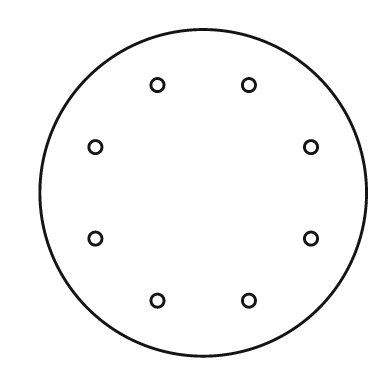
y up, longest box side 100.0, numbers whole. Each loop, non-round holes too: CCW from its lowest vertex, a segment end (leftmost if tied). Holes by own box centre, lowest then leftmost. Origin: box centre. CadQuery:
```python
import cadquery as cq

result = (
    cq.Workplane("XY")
    .moveTo(0.0, 0.0)
    .circle(50.0)
    .moveTo(-14.0, -33.0)
    .circle(2.0)
    .moveTo(14.0, -33.0)
    .circle(2.0)
    .moveTo(-33.0, -14.0)
    .circle(2.0)
    .moveTo(33.0, -14.0)
    .circle(2.0)
    .moveTo(-33.0, 14.0)
    .circle(2.0)
    .moveTo(33.0, 14.0)
    .circle(2.0)
    .moveTo(-14.0, 33.0)
    .circle(2.0)
    .moveTo(14.0, 33.0)
    .circle(2.0)
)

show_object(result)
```